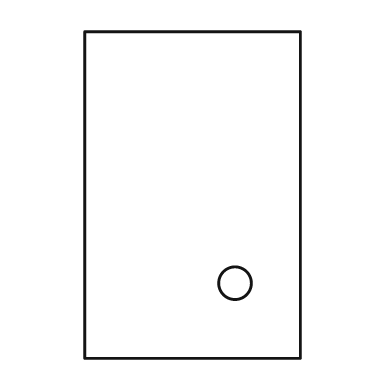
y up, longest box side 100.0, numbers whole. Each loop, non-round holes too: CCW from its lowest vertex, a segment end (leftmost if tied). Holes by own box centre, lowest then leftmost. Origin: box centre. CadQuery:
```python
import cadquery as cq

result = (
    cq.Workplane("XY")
    .moveTo(-33.0, -50.0)
    .lineTo(33.0, -50.0)
    .lineTo(33.0, 50.0)
    .lineTo(-33.0, 50.0)
    .close()
    .moveTo(13.0, -27.0)
    .circle(5.0)
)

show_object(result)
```